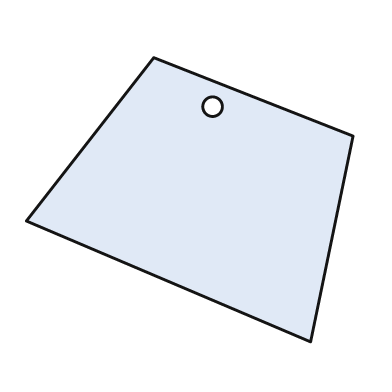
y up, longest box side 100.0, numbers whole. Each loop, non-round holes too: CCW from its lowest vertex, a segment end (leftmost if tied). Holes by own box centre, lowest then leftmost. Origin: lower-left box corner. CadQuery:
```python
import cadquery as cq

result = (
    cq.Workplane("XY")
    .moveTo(87.0, 0.0)
    .lineTo(100.0, 63.0)
    .lineTo(39.0, 87.0)
    .lineTo(0.0, 37.0)
    .close()
    .moveTo(57.0, 72.0)
    .circle(3.0)
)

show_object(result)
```